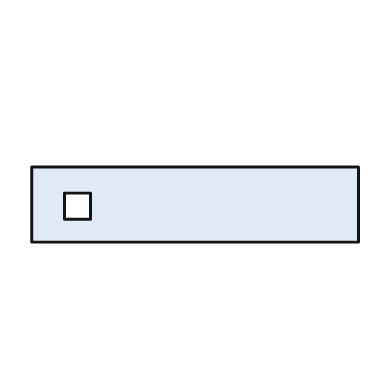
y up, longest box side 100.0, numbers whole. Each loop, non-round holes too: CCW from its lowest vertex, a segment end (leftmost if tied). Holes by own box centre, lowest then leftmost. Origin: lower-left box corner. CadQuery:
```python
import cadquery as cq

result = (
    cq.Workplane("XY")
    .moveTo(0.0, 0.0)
    .lineTo(100.0, 0.0)
    .lineTo(100.0, 23.0)
    .lineTo(0.0, 23.0)
    .close()
    .moveTo(10.0, 7.0)
    .lineTo(18.0, 7.0)
    .lineTo(18.0, 15.0)
    .lineTo(10.0, 15.0)
    .close()
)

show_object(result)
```